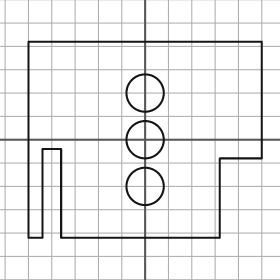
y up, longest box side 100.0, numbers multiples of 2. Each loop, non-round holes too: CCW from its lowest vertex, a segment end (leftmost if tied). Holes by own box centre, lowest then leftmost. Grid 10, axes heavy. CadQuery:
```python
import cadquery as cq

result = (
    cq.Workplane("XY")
    .moveTo(-50.0, -42.0)
    .lineTo(-44.0, -42.0)
    .lineTo(-44.0, -4.0)
    .lineTo(-36.0, -4.0)
    .lineTo(-36.0, -42.0)
    .lineTo(32.0, -42.0)
    .lineTo(32.0, -8.0)
    .lineTo(50.0, -8.0)
    .lineTo(50.0, 42.0)
    .lineTo(-50.0, 42.0)
    .close()
    .moveTo(0.0, -20.0)
    .circle(8.0)
    .moveTo(0.0, 0.0)
    .circle(8.0)
    .moveTo(0.0, 20.0)
    .circle(8.0)
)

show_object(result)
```